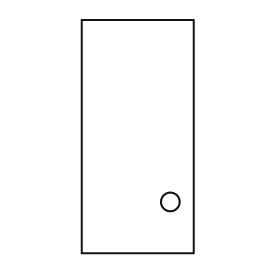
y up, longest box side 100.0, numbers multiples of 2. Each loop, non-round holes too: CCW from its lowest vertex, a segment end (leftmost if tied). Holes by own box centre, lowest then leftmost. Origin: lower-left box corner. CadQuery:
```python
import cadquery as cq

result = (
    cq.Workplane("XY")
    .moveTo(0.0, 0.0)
    .lineTo(48.0, 0.0)
    .lineTo(48.0, 100.0)
    .lineTo(0.0, 100.0)
    .close()
    .moveTo(38.0, 22.0)
    .circle(4.0)
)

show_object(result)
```